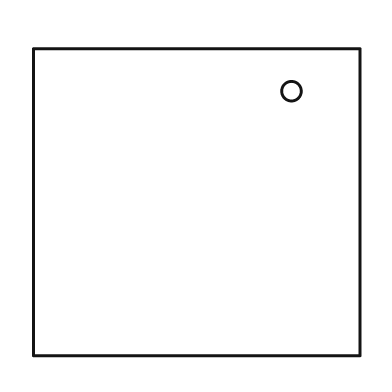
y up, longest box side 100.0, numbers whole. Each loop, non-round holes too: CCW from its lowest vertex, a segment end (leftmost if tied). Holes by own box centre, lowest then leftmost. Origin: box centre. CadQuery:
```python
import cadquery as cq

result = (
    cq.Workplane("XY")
    .moveTo(-50.0, -47.0)
    .lineTo(50.0, -47.0)
    .lineTo(50.0, 47.0)
    .lineTo(-50.0, 47.0)
    .close()
    .moveTo(29.0, 34.0)
    .circle(3.0)
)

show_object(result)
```